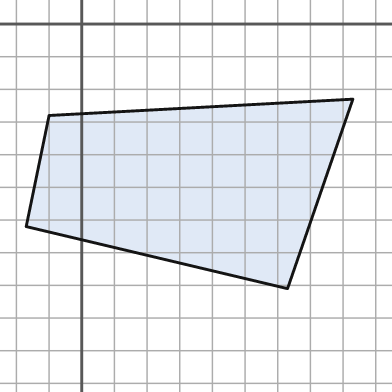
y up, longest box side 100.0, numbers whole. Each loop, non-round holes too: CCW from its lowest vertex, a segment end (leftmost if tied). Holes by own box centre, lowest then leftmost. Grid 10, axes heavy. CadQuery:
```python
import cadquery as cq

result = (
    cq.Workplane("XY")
    .moveTo(63.0, -81.0)
    .lineTo(83.0, -23.0)
    .lineTo(-10.0, -28.0)
    .lineTo(-17.0, -62.0)
    .close()
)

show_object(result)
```